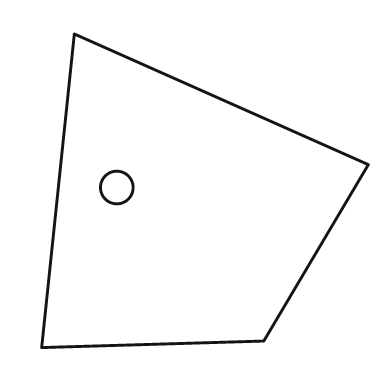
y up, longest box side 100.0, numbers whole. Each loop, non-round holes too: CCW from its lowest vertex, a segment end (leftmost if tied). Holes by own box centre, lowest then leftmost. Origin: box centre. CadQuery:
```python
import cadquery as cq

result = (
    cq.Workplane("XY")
    .moveTo(-50.0, -48.0)
    .lineTo(18.0, -46.0)
    .lineTo(50.0, 8.0)
    .lineTo(-40.0, 48.0)
    .close()
    .moveTo(-27.0, 1.0)
    .circle(5.0)
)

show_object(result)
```